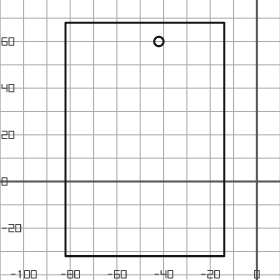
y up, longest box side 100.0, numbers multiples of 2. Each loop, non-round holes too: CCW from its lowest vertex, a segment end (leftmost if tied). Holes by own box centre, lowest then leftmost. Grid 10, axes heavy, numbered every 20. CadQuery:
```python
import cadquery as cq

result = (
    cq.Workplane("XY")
    .moveTo(-82.0, -32.0)
    .lineTo(-14.0, -32.0)
    .lineTo(-14.0, 68.0)
    .lineTo(-82.0, 68.0)
    .close()
    .moveTo(-42.0, 60.0)
    .circle(2.0)
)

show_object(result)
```